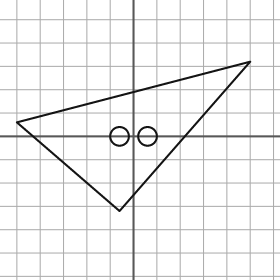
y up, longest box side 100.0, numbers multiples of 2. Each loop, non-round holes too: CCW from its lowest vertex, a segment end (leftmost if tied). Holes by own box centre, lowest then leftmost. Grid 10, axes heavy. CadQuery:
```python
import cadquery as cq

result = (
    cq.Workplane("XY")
    .moveTo(-6.0, -32.0)
    .lineTo(50.0, 32.0)
    .lineTo(-50.0, 6.0)
    .close()
    .moveTo(-6.0, 0.0)
    .circle(4.0)
    .moveTo(6.0, 0.0)
    .circle(4.0)
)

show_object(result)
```